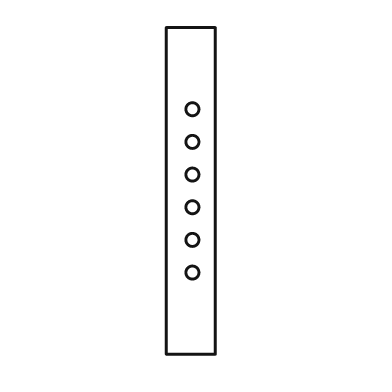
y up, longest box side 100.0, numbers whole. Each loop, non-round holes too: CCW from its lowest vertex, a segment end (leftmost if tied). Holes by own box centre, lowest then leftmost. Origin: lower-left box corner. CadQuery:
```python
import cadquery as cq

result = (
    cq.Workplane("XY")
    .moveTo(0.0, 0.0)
    .lineTo(15.0, 0.0)
    .lineTo(15.0, 100.0)
    .lineTo(0.0, 100.0)
    .close()
    .moveTo(8.0, 25.0)
    .circle(2.0)
    .moveTo(8.0, 35.0)
    .circle(2.0)
    .moveTo(8.0, 45.0)
    .circle(2.0)
    .moveTo(8.0, 55.0)
    .circle(2.0)
    .moveTo(8.0, 65.0)
    .circle(2.0)
    .moveTo(8.0, 75.0)
    .circle(2.0)
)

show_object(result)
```